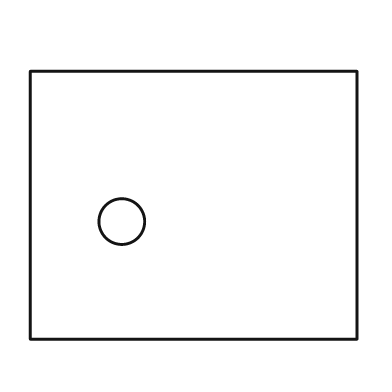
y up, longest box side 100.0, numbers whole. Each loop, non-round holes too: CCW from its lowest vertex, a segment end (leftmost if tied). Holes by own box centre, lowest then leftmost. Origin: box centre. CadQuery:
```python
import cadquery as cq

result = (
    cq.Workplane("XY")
    .moveTo(-50.0, -41.0)
    .lineTo(50.0, -41.0)
    .lineTo(50.0, 41.0)
    .lineTo(-50.0, 41.0)
    .close()
    .moveTo(-22.0, -5.0)
    .circle(7.0)
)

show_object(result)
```